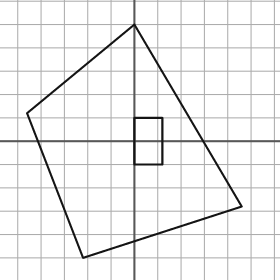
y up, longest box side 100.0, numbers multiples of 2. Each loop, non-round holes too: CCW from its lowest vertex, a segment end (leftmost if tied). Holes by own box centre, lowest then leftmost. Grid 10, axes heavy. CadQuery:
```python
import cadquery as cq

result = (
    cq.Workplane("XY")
    .moveTo(-22.0, -50.0)
    .lineTo(46.0, -28.0)
    .lineTo(0.0, 50.0)
    .lineTo(-46.0, 12.0)
    .close()
    .moveTo(0.0, -10.0)
    .lineTo(12.0, -10.0)
    .lineTo(12.0, 10.0)
    .lineTo(0.0, 10.0)
    .close()
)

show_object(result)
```